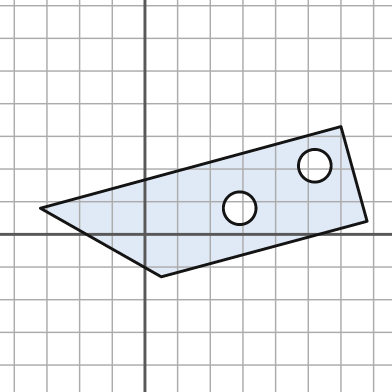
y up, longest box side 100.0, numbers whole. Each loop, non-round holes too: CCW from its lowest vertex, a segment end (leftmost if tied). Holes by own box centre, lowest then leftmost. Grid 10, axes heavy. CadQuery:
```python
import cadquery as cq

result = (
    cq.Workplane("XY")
    .moveTo(5.0, -13.0)
    .lineTo(68.0, 4.0)
    .lineTo(60.0, 33.0)
    .lineTo(-32.0, 8.0)
    .close()
    .moveTo(29.0, 8.0)
    .circle(5.0)
    .moveTo(52.0, 21.0)
    .circle(5.0)
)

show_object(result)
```